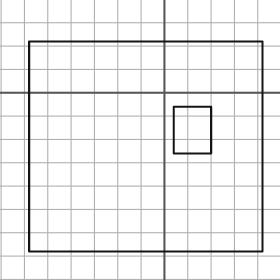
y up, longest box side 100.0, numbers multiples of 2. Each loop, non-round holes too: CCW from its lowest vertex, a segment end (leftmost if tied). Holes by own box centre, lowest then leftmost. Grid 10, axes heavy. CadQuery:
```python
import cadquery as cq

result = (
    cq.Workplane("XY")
    .moveTo(-58.0, -68.0)
    .lineTo(42.0, -68.0)
    .lineTo(42.0, 22.0)
    .lineTo(-58.0, 22.0)
    .close()
    .moveTo(4.0, -26.0)
    .lineTo(20.0, -26.0)
    .lineTo(20.0, -6.0)
    .lineTo(4.0, -6.0)
    .close()
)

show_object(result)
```